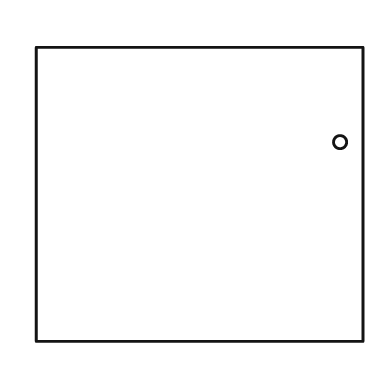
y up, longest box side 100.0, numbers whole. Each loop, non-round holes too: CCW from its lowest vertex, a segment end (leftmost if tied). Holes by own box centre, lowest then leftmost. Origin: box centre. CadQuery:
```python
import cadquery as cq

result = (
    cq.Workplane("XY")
    .moveTo(-50.0, -45.0)
    .lineTo(50.0, -45.0)
    .lineTo(50.0, 45.0)
    .lineTo(-50.0, 45.0)
    .close()
    .moveTo(43.0, 16.0)
    .circle(2.0)
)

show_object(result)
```